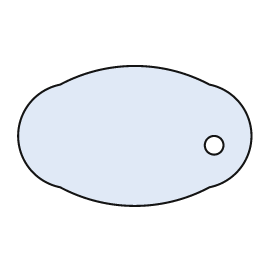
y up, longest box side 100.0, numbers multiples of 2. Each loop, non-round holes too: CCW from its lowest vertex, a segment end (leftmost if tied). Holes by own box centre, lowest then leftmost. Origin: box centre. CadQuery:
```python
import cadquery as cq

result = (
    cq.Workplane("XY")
    .moveTo(-32.0, -22.0)
    .threePointArc((0.0, -30.0), (32.0, -22.0))
    .threePointArc((50.0, 0.0), (32.0, 22.0))
    .threePointArc((0.0, 30.0), (-32.0, 22.0))
    .threePointArc((-50.0, 0.0), (-32.0, -22.0))
    .close()
    .moveTo(34.0, -4.0)
    .circle(4.0)
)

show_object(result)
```